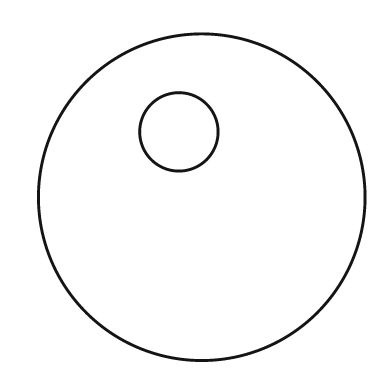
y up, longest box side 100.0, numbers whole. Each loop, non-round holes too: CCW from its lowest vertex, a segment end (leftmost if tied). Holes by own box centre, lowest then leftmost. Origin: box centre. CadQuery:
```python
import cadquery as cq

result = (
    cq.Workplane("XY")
    .moveTo(0.0, 0.0)
    .circle(50.0)
    .moveTo(-7.0, 20.0)
    .circle(12.0)
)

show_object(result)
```